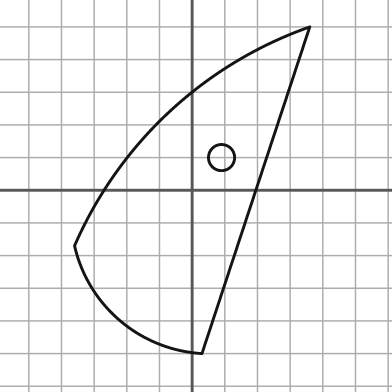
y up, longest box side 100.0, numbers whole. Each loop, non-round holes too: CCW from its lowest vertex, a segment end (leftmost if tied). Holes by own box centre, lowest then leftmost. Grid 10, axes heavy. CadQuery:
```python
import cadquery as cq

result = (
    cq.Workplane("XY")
    .moveTo(3.0, -50.0)
    .lineTo(36.0, 50.0)
    .threePointArc((-7.0, 24.0), (-36.0, -17.0))
    .threePointArc((-22.0, -40.0), (3.0, -50.0))
    .close()
    .moveTo(9.0, 10.0)
    .circle(4.0)
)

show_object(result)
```